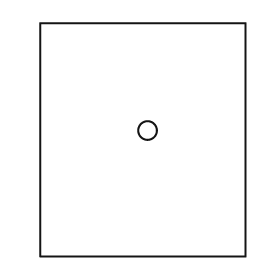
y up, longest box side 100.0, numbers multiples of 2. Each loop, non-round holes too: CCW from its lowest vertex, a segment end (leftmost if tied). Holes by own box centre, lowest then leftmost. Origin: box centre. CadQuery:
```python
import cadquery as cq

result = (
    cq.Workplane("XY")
    .moveTo(-44.0, -50.0)
    .lineTo(44.0, -50.0)
    .lineTo(44.0, 50.0)
    .lineTo(-44.0, 50.0)
    .close()
    .moveTo(2.0, 4.0)
    .circle(4.0)
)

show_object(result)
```